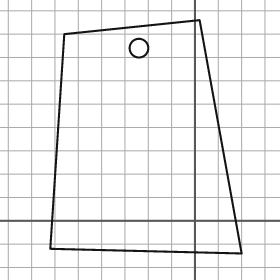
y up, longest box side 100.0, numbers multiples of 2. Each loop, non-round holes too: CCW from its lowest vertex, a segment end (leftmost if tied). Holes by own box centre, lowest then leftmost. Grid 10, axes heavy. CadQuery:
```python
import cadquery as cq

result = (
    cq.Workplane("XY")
    .moveTo(20.0, -14.0)
    .lineTo(2.0, 86.0)
    .lineTo(-56.0, 80.0)
    .lineTo(-62.0, -12.0)
    .close()
    .moveTo(-24.0, 74.0)
    .circle(4.0)
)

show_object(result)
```